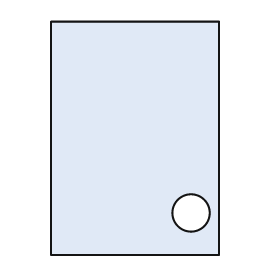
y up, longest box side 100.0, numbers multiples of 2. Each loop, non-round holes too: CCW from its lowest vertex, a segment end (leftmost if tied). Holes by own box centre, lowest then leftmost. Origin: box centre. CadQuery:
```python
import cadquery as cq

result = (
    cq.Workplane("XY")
    .moveTo(-36.0, -50.0)
    .lineTo(36.0, -50.0)
    .lineTo(36.0, 50.0)
    .lineTo(-36.0, 50.0)
    .close()
    .moveTo(24.0, -32.0)
    .circle(8.0)
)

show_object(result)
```